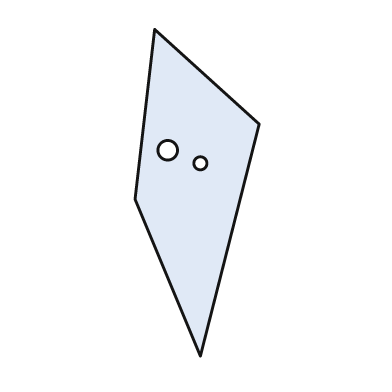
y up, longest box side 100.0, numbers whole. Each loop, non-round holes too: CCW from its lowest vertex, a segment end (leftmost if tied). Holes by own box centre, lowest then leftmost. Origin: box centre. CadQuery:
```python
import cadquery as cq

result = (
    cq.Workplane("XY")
    .moveTo(1.0, -50.0)
    .lineTo(19.0, 21.0)
    .lineTo(-13.0, 50.0)
    .lineTo(-19.0, -2.0)
    .close()
    .moveTo(1.0, 9.0)
    .circle(2.0)
    .moveTo(-9.0, 13.0)
    .circle(3.0)
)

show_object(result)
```